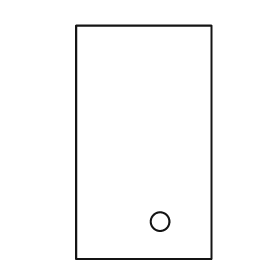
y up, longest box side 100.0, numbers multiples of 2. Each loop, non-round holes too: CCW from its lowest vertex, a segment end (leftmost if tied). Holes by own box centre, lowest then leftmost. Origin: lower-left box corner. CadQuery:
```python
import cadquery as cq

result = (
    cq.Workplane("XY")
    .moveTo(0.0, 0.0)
    .lineTo(58.0, 0.0)
    .lineTo(58.0, 100.0)
    .lineTo(0.0, 100.0)
    .close()
    .moveTo(36.0, 16.0)
    .circle(4.0)
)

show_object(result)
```